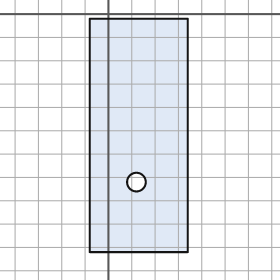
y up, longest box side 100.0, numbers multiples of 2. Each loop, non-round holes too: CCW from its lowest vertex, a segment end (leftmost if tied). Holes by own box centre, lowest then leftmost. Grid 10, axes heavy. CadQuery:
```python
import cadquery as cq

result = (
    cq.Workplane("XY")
    .moveTo(-8.0, -102.0)
    .lineTo(34.0, -102.0)
    .lineTo(34.0, -2.0)
    .lineTo(-8.0, -2.0)
    .close()
    .moveTo(12.0, -72.0)
    .circle(4.0)
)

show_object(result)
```